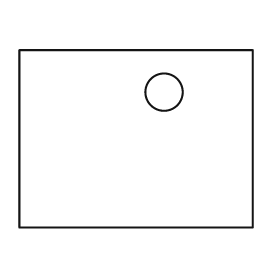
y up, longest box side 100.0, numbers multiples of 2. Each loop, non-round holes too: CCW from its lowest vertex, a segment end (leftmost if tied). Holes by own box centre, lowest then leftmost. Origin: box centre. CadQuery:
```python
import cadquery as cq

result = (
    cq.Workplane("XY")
    .moveTo(-50.0, -38.0)
    .lineTo(50.0, -38.0)
    .lineTo(50.0, 38.0)
    .lineTo(-50.0, 38.0)
    .close()
    .moveTo(12.0, 20.0)
    .circle(8.0)
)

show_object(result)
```